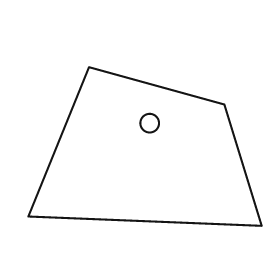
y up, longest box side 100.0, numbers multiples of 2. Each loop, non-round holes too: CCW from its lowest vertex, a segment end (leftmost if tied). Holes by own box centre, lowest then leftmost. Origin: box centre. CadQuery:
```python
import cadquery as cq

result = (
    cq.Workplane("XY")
    .moveTo(50.0, -34.0)
    .lineTo(34.0, 18.0)
    .lineTo(-24.0, 34.0)
    .lineTo(-50.0, -30.0)
    .close()
    .moveTo(2.0, 10.0)
    .circle(4.0)
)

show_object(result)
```